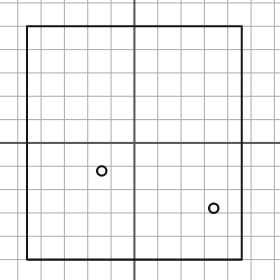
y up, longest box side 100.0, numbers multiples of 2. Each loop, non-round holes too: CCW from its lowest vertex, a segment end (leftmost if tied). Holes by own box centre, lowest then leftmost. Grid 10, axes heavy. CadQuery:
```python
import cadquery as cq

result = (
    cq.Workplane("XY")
    .moveTo(-46.0, -50.0)
    .lineTo(46.0, -50.0)
    .lineTo(46.0, 50.0)
    .lineTo(-46.0, 50.0)
    .close()
    .moveTo(34.0, -28.0)
    .circle(2.0)
    .moveTo(-14.0, -12.0)
    .circle(2.0)
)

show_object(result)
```